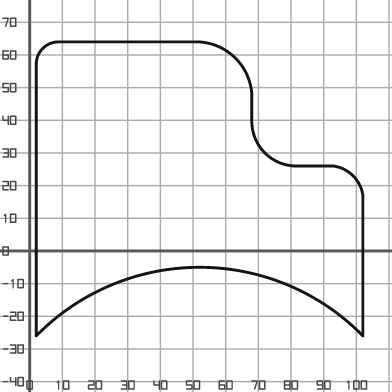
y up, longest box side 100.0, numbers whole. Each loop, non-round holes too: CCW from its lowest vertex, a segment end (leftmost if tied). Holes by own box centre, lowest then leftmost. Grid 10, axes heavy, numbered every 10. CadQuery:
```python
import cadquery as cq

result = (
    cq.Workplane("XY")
    .moveTo(2.0, -26.0)
    .threePointArc((52.0, -5.0), (102.0, -26.0))
    .lineTo(102.0, 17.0)
    .threePointArc((99.0, 23.0), (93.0, 26.0))
    .lineTo(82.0, 26.0)
    .threePointArc((72.0, 30.0), (68.0, 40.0))
    .lineTo(68.0, 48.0)
    .threePointArc((63.0, 59.0), (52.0, 64.0))
    .lineTo(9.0, 64.0)
    .threePointArc((4.0, 62.0), (2.0, 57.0))
    .close()
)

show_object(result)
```